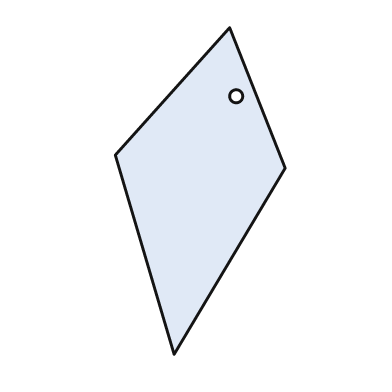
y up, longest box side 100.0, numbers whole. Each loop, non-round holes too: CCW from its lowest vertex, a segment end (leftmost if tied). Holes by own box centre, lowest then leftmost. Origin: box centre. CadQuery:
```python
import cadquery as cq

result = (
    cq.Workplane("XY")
    .moveTo(-8.0, -50.0)
    .lineTo(26.0, 7.0)
    .lineTo(9.0, 50.0)
    .lineTo(-26.0, 11.0)
    .close()
    .moveTo(11.0, 29.0)
    .circle(2.0)
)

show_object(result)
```